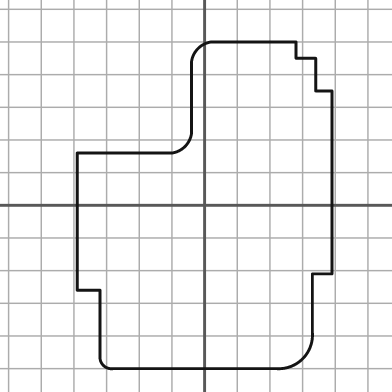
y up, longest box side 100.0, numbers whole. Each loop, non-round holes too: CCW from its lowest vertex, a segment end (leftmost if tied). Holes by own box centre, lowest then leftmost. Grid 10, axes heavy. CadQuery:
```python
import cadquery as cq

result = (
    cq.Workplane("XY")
    .moveTo(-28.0, -50.0)
    .lineTo(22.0, -50.0)
    .threePointArc((30.0, -47.0), (33.0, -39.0))
    .lineTo(33.0, -21.0)
    .lineTo(39.0, -21.0)
    .lineTo(39.0, 35.0)
    .lineTo(34.0, 35.0)
    .lineTo(34.0, 45.0)
    .lineTo(28.0, 45.0)
    .lineTo(28.0, 50.0)
    .lineTo(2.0, 50.0)
    .threePointArc((-2.0, 48.0), (-4.0, 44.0))
    .lineTo(-4.0, 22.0)
    .threePointArc((-6.0, 18.0), (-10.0, 16.0))
    .lineTo(-39.0, 16.0)
    .lineTo(-39.0, -26.0)
    .lineTo(-32.0, -26.0)
    .lineTo(-32.0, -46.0)
    .threePointArc((-31.0, -49.0), (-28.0, -50.0))
    .close()
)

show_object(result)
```